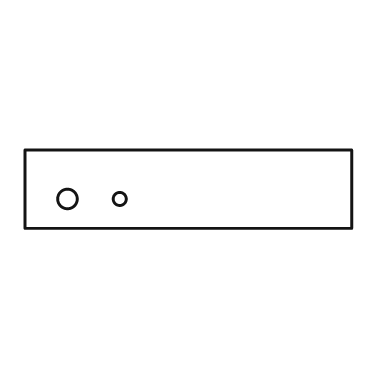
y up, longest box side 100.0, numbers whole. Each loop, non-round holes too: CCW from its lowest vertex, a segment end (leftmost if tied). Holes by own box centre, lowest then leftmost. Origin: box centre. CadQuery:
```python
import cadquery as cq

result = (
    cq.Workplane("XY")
    .moveTo(-50.0, -12.0)
    .lineTo(50.0, -12.0)
    .lineTo(50.0, 12.0)
    .lineTo(-50.0, 12.0)
    .close()
    .moveTo(-37.0, -3.0)
    .circle(3.0)
    .moveTo(-21.0, -3.0)
    .circle(2.0)
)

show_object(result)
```